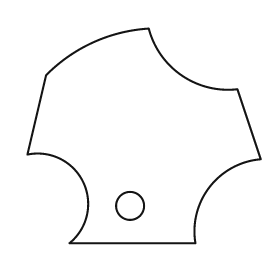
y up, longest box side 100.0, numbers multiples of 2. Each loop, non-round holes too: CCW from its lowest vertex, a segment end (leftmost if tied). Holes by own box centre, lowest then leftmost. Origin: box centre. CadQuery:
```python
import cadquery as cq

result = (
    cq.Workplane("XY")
    .moveTo(-32.0, -46.0)
    .lineTo(22.0, -46.0)
    .threePointArc((28.0, -22.0), (50.0, -10.0))
    .lineTo(40.0, 20.0)
    .threePointArc((16.0, 26.0), (2.0, 46.0))
    .threePointArc((-22.0, 40.0), (-42.0, 26.0))
    .lineTo(-50.0, -8.0)
    .threePointArc((-26.0, -20.0), (-32.0, -46.0))
    .close()
    .moveTo(-6.0, -30.0)
    .circle(6.0)
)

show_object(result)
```